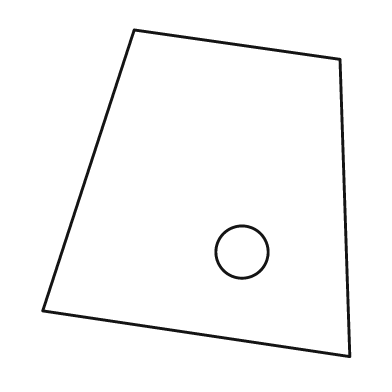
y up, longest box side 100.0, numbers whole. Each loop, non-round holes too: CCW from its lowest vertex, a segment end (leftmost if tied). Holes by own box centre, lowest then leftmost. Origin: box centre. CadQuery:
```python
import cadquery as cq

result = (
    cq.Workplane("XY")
    .moveTo(47.0, -50.0)
    .lineTo(44.0, 41.0)
    .lineTo(-19.0, 50.0)
    .lineTo(-47.0, -36.0)
    .close()
    .moveTo(14.0, -18.0)
    .circle(8.0)
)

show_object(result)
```